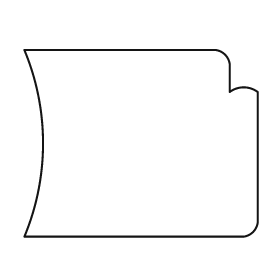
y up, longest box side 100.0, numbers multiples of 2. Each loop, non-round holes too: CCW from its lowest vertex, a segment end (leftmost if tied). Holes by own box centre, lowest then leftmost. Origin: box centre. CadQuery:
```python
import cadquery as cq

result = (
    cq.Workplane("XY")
    .moveTo(-50.0, -40.0)
    .lineTo(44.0, -40.0)
    .threePointArc((48.0, -38.0), (50.0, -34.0))
    .lineTo(50.0, 22.0)
    .threePointArc((44.0, 24.0), (38.0, 22.0))
    .lineTo(38.0, 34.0)
    .threePointArc((36.0, 38.0), (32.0, 40.0))
    .lineTo(-50.0, 40.0)
    .threePointArc((-42.0, 0.0), (-50.0, -40.0))
    .close()
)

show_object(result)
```